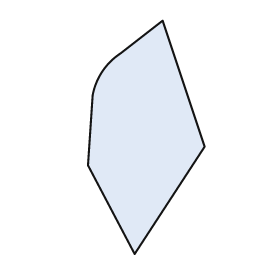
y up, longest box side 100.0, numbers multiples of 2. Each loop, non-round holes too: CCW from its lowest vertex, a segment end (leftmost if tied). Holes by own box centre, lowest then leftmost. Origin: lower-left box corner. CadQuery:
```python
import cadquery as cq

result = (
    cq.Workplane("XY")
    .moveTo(20.0, 0.0)
    .lineTo(50.0, 46.0)
    .lineTo(32.0, 100.0)
    .lineTo(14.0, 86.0)
    .threePointArc((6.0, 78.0), (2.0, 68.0))
    .lineTo(0.0, 38.0)
    .close()
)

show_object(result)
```